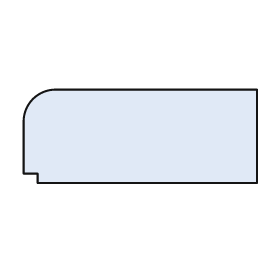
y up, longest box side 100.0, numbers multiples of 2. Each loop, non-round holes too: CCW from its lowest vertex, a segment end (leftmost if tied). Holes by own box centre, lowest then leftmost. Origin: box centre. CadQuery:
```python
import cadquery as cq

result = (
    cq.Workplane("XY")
    .moveTo(-44.0, -20.0)
    .lineTo(50.0, -20.0)
    .lineTo(50.0, 20.0)
    .lineTo(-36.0, 20.0)
    .threePointArc((-46.0, 16.0), (-50.0, 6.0))
    .lineTo(-50.0, -16.0)
    .lineTo(-44.0, -16.0)
    .close()
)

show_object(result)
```